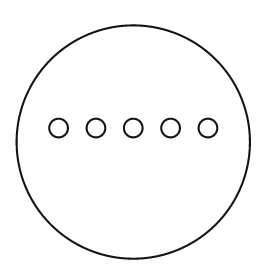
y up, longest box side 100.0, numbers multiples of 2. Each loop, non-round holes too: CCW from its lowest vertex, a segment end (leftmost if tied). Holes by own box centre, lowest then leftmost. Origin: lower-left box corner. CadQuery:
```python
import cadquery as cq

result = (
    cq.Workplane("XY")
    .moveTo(50.0, 50.0)
    .circle(50.0)
    .moveTo(18.0, 56.0)
    .circle(4.0)
    .moveTo(34.0, 56.0)
    .circle(4.0)
    .moveTo(50.0, 56.0)
    .circle(4.0)
    .moveTo(66.0, 56.0)
    .circle(4.0)
    .moveTo(82.0, 56.0)
    .circle(4.0)
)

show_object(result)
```